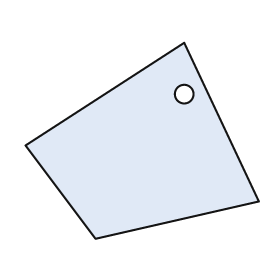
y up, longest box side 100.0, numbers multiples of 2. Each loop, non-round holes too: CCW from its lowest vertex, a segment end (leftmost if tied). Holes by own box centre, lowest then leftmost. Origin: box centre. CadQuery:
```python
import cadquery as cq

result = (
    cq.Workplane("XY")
    .moveTo(-20.0, -42.0)
    .lineTo(50.0, -26.0)
    .lineTo(18.0, 42.0)
    .lineTo(-50.0, -2.0)
    .close()
    .moveTo(18.0, 20.0)
    .circle(4.0)
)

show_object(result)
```